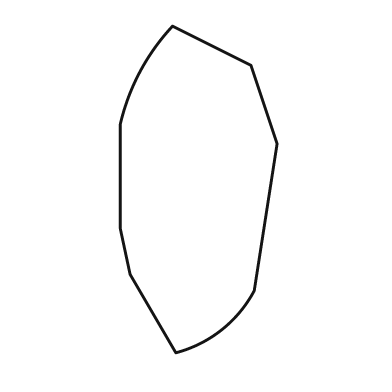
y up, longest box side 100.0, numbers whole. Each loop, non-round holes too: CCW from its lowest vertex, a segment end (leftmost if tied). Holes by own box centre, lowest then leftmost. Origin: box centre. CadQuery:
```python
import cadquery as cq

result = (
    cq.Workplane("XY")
    .moveTo(-7.0, -50.0)
    .threePointArc((7.0, -43.0), (17.0, -31.0))
    .lineTo(24.0, 14.0)
    .lineTo(16.0, 38.0)
    .lineTo(-8.0, 50.0)
    .threePointArc((-18.0, 36.0), (-24.0, 20.0))
    .lineTo(-24.0, -12.0)
    .lineTo(-21.0, -26.0)
    .close()
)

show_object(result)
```